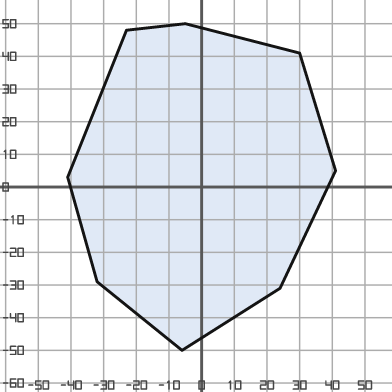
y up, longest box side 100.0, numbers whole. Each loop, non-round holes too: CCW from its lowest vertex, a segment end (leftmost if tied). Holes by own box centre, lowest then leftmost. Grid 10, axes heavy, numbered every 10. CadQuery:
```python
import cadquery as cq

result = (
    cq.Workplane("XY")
    .moveTo(-6.0, -50.0)
    .lineTo(24.0, -31.0)
    .lineTo(41.0, 5.0)
    .lineTo(30.0, 41.0)
    .lineTo(-5.0, 50.0)
    .lineTo(-23.0, 48.0)
    .lineTo(-41.0, 3.0)
    .lineTo(-32.0, -29.0)
    .close()
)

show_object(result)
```